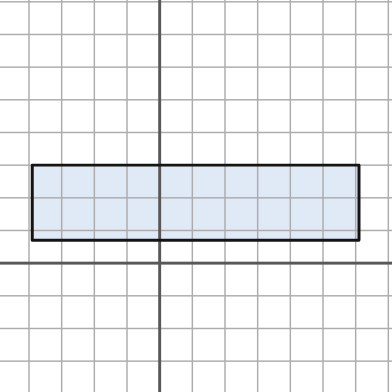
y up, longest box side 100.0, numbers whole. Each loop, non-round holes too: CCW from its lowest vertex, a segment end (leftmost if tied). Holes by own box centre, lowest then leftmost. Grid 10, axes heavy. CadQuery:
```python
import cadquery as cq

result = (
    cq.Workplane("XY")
    .moveTo(-39.0, 7.0)
    .lineTo(61.0, 7.0)
    .lineTo(61.0, 30.0)
    .lineTo(-39.0, 30.0)
    .close()
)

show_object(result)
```